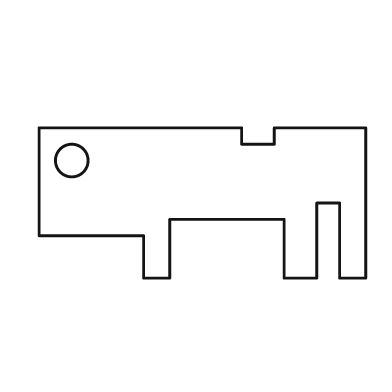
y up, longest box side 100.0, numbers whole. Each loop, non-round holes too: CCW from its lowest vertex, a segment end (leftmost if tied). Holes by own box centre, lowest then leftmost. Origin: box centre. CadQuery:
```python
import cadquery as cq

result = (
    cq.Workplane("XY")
    .moveTo(-18.0, -23.0)
    .lineTo(-10.0, -23.0)
    .lineTo(-10.0, -5.0)
    .lineTo(25.0, -5.0)
    .lineTo(25.0, -23.0)
    .lineTo(35.0, -23.0)
    .lineTo(35.0, 0.0)
    .lineTo(42.0, 0.0)
    .lineTo(42.0, -23.0)
    .lineTo(50.0, -23.0)
    .lineTo(50.0, 23.0)
    .lineTo(22.0, 23.0)
    .lineTo(22.0, 18.0)
    .lineTo(12.0, 18.0)
    .lineTo(12.0, 23.0)
    .lineTo(-50.0, 23.0)
    .lineTo(-50.0, -10.0)
    .lineTo(-18.0, -10.0)
    .close()
    .moveTo(-40.0, 13.0)
    .circle(5.0)
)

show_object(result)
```